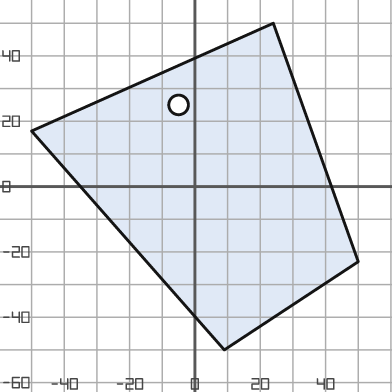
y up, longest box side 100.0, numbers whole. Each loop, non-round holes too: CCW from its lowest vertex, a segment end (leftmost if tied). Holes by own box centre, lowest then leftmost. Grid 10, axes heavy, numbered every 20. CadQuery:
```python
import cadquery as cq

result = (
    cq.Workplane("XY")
    .moveTo(9.0, -50.0)
    .lineTo(50.0, -23.0)
    .lineTo(24.0, 50.0)
    .lineTo(-50.0, 17.0)
    .close()
    .moveTo(-5.0, 25.0)
    .circle(3.0)
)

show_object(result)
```